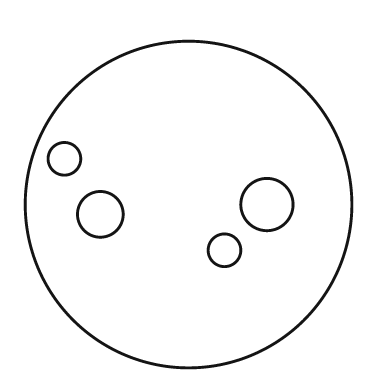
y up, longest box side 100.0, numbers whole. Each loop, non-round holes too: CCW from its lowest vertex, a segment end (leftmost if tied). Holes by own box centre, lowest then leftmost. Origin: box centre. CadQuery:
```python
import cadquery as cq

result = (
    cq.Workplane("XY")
    .moveTo(0.0, 0.0)
    .circle(50.0)
    .moveTo(11.0, -14.0)
    .circle(5.0)
    .moveTo(-27.0, -3.0)
    .circle(7.0)
    .moveTo(24.0, 0.0)
    .circle(8.0)
    .moveTo(-38.0, 14.0)
    .circle(5.0)
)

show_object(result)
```